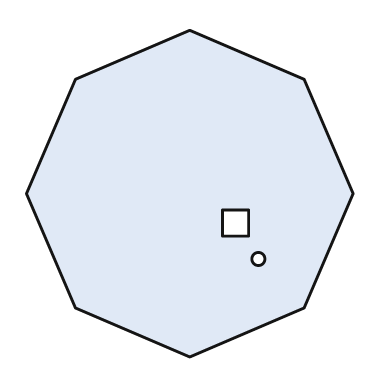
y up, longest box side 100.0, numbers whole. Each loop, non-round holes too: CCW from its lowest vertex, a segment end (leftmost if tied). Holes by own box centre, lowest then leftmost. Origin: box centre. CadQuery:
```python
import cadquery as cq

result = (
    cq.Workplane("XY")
    .moveTo(0.0, -50.0)
    .lineTo(35.0, -35.0)
    .lineTo(50.0, 0.0)
    .lineTo(35.0, 35.0)
    .lineTo(0.0, 50.0)
    .lineTo(-35.0, 35.0)
    .lineTo(-50.0, 0.0)
    .lineTo(-35.0, -35.0)
    .close()
    .moveTo(21.0, -20.0)
    .circle(2.0)
    .moveTo(10.0, -13.0)
    .lineTo(18.0, -13.0)
    .lineTo(18.0, -5.0)
    .lineTo(10.0, -5.0)
    .close()
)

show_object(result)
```